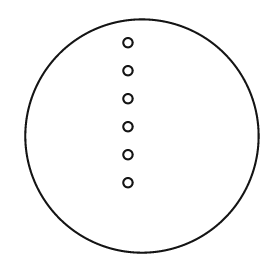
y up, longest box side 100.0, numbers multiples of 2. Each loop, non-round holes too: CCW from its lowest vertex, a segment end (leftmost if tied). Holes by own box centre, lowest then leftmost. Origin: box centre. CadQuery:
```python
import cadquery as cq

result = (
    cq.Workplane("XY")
    .moveTo(0.0, 0.0)
    .circle(50.0)
    .moveTo(-6.0, -20.0)
    .circle(2.0)
    .moveTo(-6.0, -8.0)
    .circle(2.0)
    .moveTo(-6.0, 4.0)
    .circle(2.0)
    .moveTo(-6.0, 16.0)
    .circle(2.0)
    .moveTo(-6.0, 28.0)
    .circle(2.0)
    .moveTo(-6.0, 40.0)
    .circle(2.0)
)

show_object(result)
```